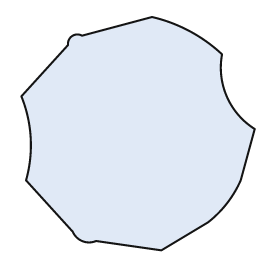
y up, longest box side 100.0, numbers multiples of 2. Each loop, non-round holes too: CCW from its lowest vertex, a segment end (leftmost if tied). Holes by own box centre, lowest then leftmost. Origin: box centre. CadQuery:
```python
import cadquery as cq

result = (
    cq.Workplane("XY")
    .moveTo(10.0, -50.0)
    .lineTo(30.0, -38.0)
    .threePointArc((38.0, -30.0), (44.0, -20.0))
    .lineTo(50.0, 2.0)
    .threePointArc((38.0, 16.0), (36.0, 34.0))
    .threePointArc((22.0, 44.0), (6.0, 50.0))
    .lineTo(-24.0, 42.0)
    .threePointArc((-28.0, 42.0), (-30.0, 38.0))
    .lineTo(-50.0, 16.0)
    .threePointArc((-46.0, -2.0), (-48.0, -20.0))
    .lineTo(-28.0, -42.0)
    .threePointArc((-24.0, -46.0), (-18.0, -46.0))
    .close()
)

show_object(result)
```